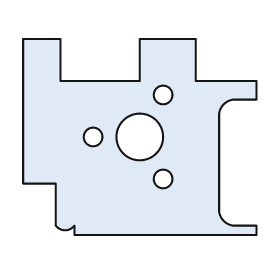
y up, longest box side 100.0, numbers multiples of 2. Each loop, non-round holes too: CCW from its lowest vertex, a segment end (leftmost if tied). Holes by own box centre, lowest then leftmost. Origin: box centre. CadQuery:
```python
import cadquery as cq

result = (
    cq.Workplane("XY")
    .moveTo(-28.0, -42.0)
    .lineTo(50.0, -42.0)
    .lineTo(50.0, -38.0)
    .lineTo(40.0, -38.0)
    .threePointArc((36.0, -36.0), (34.0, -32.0))
    .lineTo(34.0, 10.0)
    .threePointArc((36.0, 14.0), (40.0, 16.0))
    .lineTo(50.0, 16.0)
    .lineTo(50.0, 24.0)
    .lineTo(24.0, 24.0)
    .lineTo(24.0, 42.0)
    .lineTo(0.0, 42.0)
    .lineTo(0.0, 24.0)
    .lineTo(-34.0, 24.0)
    .lineTo(-34.0, 42.0)
    .lineTo(-50.0, 42.0)
    .lineTo(-50.0, -20.0)
    .lineTo(-36.0, -20.0)
    .lineTo(-36.0, -38.0)
    .threePointArc((-32.0, -40.0), (-28.0, -38.0))
    .close()
    .moveTo(10.0, -18.0)
    .circle(4.0)
    .moveTo(-20.0, 0.0)
    .circle(4.0)
    .moveTo(0.0, 0.0)
    .circle(10.0)
    .moveTo(10.0, 18.0)
    .circle(4.0)
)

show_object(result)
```